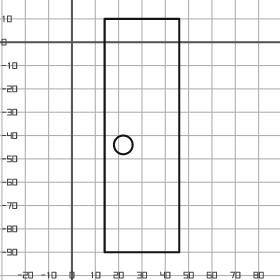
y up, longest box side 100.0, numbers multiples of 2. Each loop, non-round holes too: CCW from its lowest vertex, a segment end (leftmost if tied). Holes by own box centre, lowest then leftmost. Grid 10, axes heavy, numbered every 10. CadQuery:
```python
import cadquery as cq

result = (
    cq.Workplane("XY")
    .moveTo(14.0, -90.0)
    .lineTo(46.0, -90.0)
    .lineTo(46.0, 10.0)
    .lineTo(14.0, 10.0)
    .close()
    .moveTo(22.0, -44.0)
    .circle(4.0)
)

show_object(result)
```